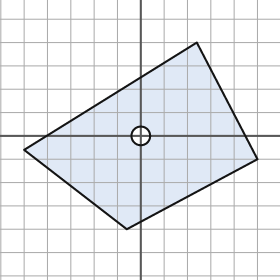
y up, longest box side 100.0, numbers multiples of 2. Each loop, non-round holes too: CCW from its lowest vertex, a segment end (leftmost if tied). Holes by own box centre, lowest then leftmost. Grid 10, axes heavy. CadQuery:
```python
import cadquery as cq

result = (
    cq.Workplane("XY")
    .moveTo(-6.0, -40.0)
    .lineTo(50.0, -10.0)
    .lineTo(24.0, 40.0)
    .lineTo(-50.0, -6.0)
    .close()
    .moveTo(0.0, 0.0)
    .circle(4.0)
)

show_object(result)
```